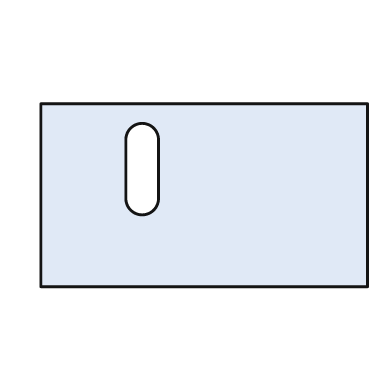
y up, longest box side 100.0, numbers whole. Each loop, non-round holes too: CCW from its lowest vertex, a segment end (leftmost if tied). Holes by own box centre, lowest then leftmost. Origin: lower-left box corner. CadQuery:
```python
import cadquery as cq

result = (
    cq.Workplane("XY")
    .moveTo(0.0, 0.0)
    .lineTo(100.0, 0.0)
    .lineTo(100.0, 56.0)
    .lineTo(0.0, 56.0)
    .close()
    .moveTo(26.0, 27.0)
    .threePointArc((31.0, 22.0), (36.0, 27.0))
    .lineTo(36.0, 45.0)
    .threePointArc((31.0, 50.0), (26.0, 45.0))
    .close()
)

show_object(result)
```